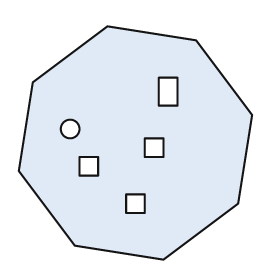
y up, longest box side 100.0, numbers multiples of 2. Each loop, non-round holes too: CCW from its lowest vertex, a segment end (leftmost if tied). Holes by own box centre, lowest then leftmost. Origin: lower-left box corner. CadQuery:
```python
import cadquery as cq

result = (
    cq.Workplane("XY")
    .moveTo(62.0, 0.0)
    .lineTo(94.0, 24.0)
    .lineTo(100.0, 62.0)
    .lineTo(76.0, 94.0)
    .lineTo(38.0, 100.0)
    .lineTo(6.0, 76.0)
    .lineTo(0.0, 38.0)
    .lineTo(24.0, 6.0)
    .close()
    .moveTo(46.0, 20.0)
    .lineTo(54.0, 20.0)
    .lineTo(54.0, 28.0)
    .lineTo(46.0, 28.0)
    .close()
    .moveTo(26.0, 36.0)
    .lineTo(34.0, 36.0)
    .lineTo(34.0, 44.0)
    .lineTo(26.0, 44.0)
    .close()
    .moveTo(54.0, 44.0)
    .lineTo(62.0, 44.0)
    .lineTo(62.0, 52.0)
    .lineTo(54.0, 52.0)
    .close()
    .moveTo(22.0, 56.0)
    .circle(4.0)
    .moveTo(60.0, 66.0)
    .lineTo(68.0, 66.0)
    .lineTo(68.0, 78.0)
    .lineTo(60.0, 78.0)
    .close()
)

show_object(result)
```